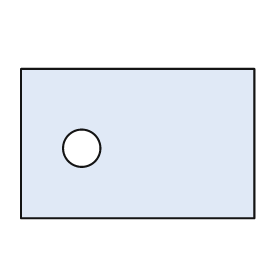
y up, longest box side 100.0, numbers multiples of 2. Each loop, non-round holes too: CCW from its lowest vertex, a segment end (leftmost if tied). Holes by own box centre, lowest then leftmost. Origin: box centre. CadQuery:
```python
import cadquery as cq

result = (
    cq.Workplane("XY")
    .moveTo(-50.0, -32.0)
    .lineTo(50.0, -32.0)
    .lineTo(50.0, 32.0)
    .lineTo(-50.0, 32.0)
    .close()
    .moveTo(-24.0, -2.0)
    .circle(8.0)
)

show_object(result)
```